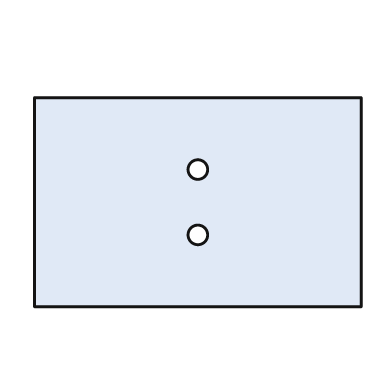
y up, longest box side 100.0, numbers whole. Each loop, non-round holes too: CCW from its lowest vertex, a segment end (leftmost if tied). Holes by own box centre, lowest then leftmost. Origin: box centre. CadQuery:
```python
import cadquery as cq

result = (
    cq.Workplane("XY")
    .moveTo(-50.0, -32.0)
    .lineTo(50.0, -32.0)
    .lineTo(50.0, 32.0)
    .lineTo(-50.0, 32.0)
    .close()
    .moveTo(0.0, -10.0)
    .circle(3.0)
    .moveTo(0.0, 10.0)
    .circle(3.0)
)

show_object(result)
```